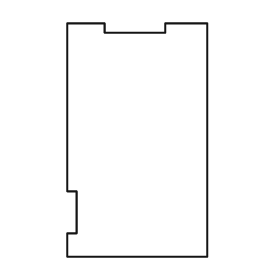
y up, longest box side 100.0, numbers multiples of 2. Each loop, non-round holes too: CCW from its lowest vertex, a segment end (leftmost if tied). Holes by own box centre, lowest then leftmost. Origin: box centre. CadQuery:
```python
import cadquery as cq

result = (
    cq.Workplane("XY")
    .moveTo(-30.0, -50.0)
    .lineTo(30.0, -50.0)
    .lineTo(30.0, 50.0)
    .lineTo(12.0, 50.0)
    .lineTo(12.0, 46.0)
    .lineTo(-14.0, 46.0)
    .lineTo(-14.0, 50.0)
    .lineTo(-30.0, 50.0)
    .lineTo(-30.0, -22.0)
    .lineTo(-26.0, -22.0)
    .lineTo(-26.0, -40.0)
    .lineTo(-30.0, -40.0)
    .close()
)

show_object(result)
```